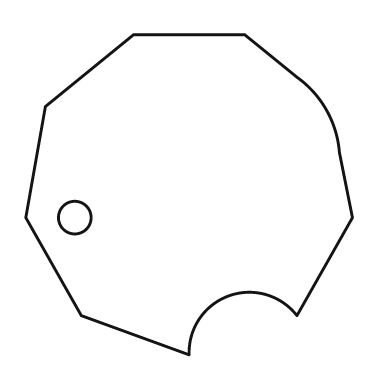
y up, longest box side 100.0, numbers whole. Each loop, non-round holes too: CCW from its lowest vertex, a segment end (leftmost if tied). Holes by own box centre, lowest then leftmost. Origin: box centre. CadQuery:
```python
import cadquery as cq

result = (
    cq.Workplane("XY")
    .moveTo(0.0, -49.0)
    .threePointArc((12.0, -31.0), (33.0, -37.0))
    .lineTo(50.0, -7.0)
    .lineTo(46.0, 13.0)
    .threePointArc((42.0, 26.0), (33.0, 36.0))
    .lineTo(17.0, 49.0)
    .lineTo(-17.0, 49.0)
    .lineTo(-44.0, 27.0)
    .lineTo(-50.0, -7.0)
    .lineTo(-33.0, -37.0)
    .close()
    .moveTo(-35.0, -7.0)
    .circle(5.0)
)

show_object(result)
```